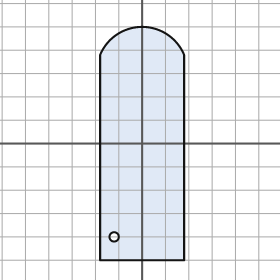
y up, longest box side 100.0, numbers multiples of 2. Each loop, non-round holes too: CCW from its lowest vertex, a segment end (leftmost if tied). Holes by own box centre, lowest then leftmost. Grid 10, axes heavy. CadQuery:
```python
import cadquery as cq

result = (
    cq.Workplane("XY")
    .moveTo(-18.0, -50.0)
    .lineTo(18.0, -50.0)
    .lineTo(18.0, 38.0)
    .threePointArc((0.0, 50.0), (-18.0, 38.0))
    .close()
    .moveTo(-12.0, -40.0)
    .circle(2.0)
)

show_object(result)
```